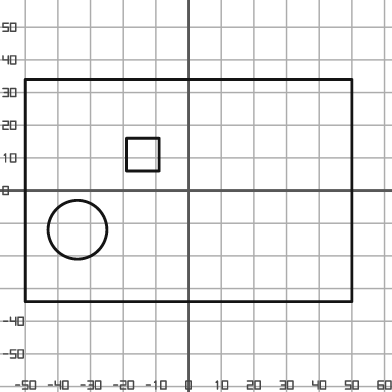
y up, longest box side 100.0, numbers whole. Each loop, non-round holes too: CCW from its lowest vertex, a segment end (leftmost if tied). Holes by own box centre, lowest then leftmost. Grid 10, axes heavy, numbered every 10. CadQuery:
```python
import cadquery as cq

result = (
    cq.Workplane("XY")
    .moveTo(-50.0, -34.0)
    .lineTo(50.0, -34.0)
    .lineTo(50.0, 34.0)
    .lineTo(-50.0, 34.0)
    .close()
    .moveTo(-34.0, -12.0)
    .circle(9.0)
    .moveTo(-19.0, 6.0)
    .lineTo(-9.0, 6.0)
    .lineTo(-9.0, 16.0)
    .lineTo(-19.0, 16.0)
    .close()
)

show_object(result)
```